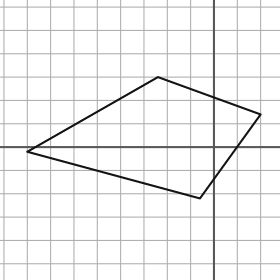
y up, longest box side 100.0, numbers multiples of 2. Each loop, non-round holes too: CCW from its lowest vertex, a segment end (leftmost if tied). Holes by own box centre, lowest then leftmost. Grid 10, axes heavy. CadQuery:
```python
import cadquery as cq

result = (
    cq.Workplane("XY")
    .moveTo(-6.0, -22.0)
    .lineTo(20.0, 14.0)
    .lineTo(-24.0, 30.0)
    .lineTo(-80.0, -2.0)
    .close()
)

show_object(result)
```